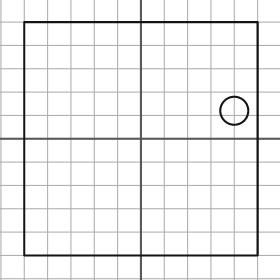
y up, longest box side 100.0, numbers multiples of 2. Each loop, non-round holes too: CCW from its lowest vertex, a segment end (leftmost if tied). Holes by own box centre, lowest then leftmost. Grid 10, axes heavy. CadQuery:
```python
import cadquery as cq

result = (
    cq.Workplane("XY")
    .moveTo(-50.0, -50.0)
    .lineTo(50.0, -50.0)
    .lineTo(50.0, 50.0)
    .lineTo(-50.0, 50.0)
    .close()
    .moveTo(40.0, 12.0)
    .circle(6.0)
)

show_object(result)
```